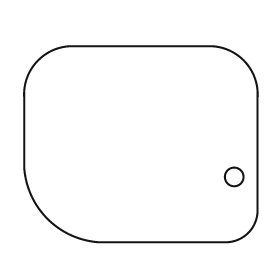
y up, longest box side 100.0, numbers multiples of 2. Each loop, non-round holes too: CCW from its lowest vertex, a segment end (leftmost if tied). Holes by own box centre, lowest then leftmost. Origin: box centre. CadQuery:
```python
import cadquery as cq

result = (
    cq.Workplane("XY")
    .moveTo(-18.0, -42.0)
    .lineTo(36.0, -42.0)
    .threePointArc((46.0, -38.0), (50.0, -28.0))
    .lineTo(50.0, 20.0)
    .threePointArc((44.0, 36.0), (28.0, 42.0))
    .lineTo(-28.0, 42.0)
    .threePointArc((-44.0, 36.0), (-50.0, 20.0))
    .lineTo(-50.0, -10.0)
    .threePointArc((-40.0, -32.0), (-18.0, -42.0))
    .close()
    .moveTo(40.0, -14.0)
    .circle(4.0)
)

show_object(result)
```